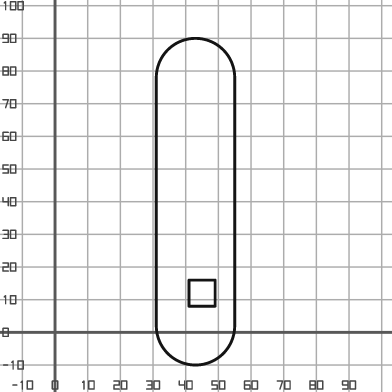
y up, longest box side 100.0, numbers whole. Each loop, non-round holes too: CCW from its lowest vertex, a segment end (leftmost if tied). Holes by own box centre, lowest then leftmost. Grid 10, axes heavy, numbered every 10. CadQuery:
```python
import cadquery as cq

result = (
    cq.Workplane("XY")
    .moveTo(31.0, 2.0)
    .threePointArc((43.0, -10.0), (55.0, 2.0))
    .lineTo(55.0, 78.0)
    .threePointArc((43.0, 90.0), (31.0, 78.0))
    .close()
    .moveTo(41.0, 8.0)
    .lineTo(49.0, 8.0)
    .lineTo(49.0, 16.0)
    .lineTo(41.0, 16.0)
    .close()
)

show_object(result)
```